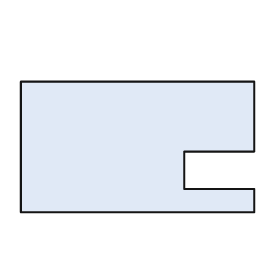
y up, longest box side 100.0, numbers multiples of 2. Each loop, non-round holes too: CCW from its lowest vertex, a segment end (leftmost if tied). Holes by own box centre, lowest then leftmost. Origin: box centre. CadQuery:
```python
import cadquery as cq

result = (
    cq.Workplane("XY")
    .moveTo(-50.0, -28.0)
    .lineTo(50.0, -28.0)
    .lineTo(50.0, -18.0)
    .lineTo(20.0, -18.0)
    .lineTo(20.0, -2.0)
    .lineTo(50.0, -2.0)
    .lineTo(50.0, 28.0)
    .lineTo(-50.0, 28.0)
    .close()
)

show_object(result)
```